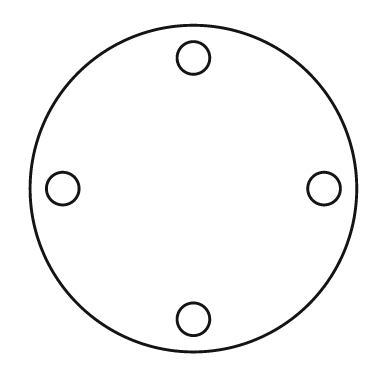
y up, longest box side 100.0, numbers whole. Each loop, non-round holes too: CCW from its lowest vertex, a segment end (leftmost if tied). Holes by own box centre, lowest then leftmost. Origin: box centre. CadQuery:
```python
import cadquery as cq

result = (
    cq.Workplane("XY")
    .moveTo(0.0, 0.0)
    .circle(50.0)
    .moveTo(0.0, -40.0)
    .circle(5.0)
    .moveTo(-40.0, 0.0)
    .circle(5.0)
    .moveTo(40.0, 0.0)
    .circle(5.0)
    .moveTo(0.0, 40.0)
    .circle(5.0)
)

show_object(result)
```